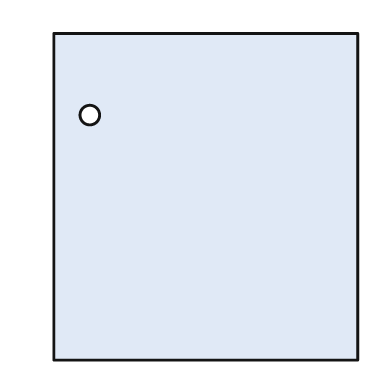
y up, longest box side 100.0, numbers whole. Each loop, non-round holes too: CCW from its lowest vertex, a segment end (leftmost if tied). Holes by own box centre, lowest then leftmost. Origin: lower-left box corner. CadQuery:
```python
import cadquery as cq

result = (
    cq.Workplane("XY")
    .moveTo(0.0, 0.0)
    .lineTo(93.0, 0.0)
    .lineTo(93.0, 100.0)
    .lineTo(0.0, 100.0)
    .close()
    .moveTo(11.0, 75.0)
    .circle(3.0)
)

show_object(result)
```